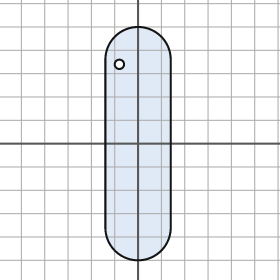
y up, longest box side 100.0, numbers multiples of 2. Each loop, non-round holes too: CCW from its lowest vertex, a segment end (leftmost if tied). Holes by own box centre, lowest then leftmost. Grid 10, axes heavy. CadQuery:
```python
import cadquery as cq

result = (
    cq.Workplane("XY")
    .moveTo(-14.0, -36.0)
    .threePointArc((0.0, -50.0), (14.0, -36.0))
    .lineTo(14.0, 36.0)
    .threePointArc((0.0, 50.0), (-14.0, 36.0))
    .close()
    .moveTo(-8.0, 34.0)
    .circle(2.0)
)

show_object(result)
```